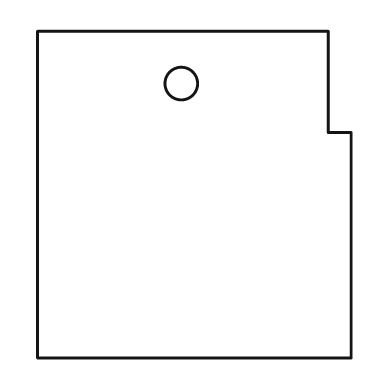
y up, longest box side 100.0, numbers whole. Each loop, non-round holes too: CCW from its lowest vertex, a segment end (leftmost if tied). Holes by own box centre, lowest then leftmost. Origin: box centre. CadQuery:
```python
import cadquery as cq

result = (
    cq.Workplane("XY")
    .moveTo(-48.0, -50.0)
    .lineTo(48.0, -50.0)
    .lineTo(48.0, 19.0)
    .lineTo(41.0, 19.0)
    .lineTo(41.0, 50.0)
    .lineTo(-48.0, 50.0)
    .close()
    .moveTo(-4.0, 34.0)
    .circle(5.0)
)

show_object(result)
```